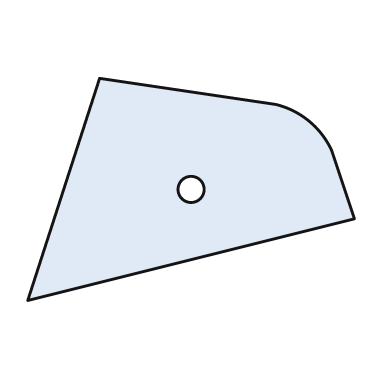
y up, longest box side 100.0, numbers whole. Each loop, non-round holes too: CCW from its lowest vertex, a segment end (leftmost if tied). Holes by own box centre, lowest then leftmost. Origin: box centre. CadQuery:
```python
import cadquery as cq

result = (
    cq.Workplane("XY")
    .moveTo(-50.0, -34.0)
    .lineTo(50.0, -9.0)
    .lineTo(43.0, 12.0)
    .threePointArc((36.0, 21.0), (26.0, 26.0))
    .lineTo(-28.0, 34.0)
    .close()
    .moveTo(0.0, 0.0)
    .circle(4.0)
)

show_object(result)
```